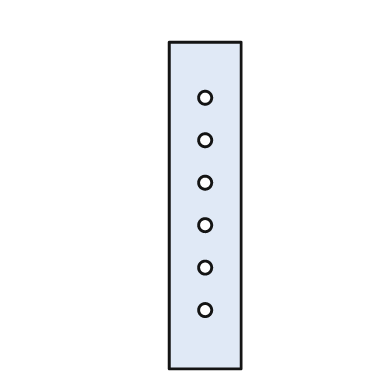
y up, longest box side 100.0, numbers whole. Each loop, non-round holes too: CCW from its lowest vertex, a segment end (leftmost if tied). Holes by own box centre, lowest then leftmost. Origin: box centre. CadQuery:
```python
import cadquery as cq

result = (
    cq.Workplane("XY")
    .moveTo(-11.0, -50.0)
    .lineTo(11.0, -50.0)
    .lineTo(11.0, 50.0)
    .lineTo(-11.0, 50.0)
    .close()
    .moveTo(0.0, -32.0)
    .circle(2.0)
    .moveTo(0.0, -19.0)
    .circle(2.0)
    .moveTo(0.0, -6.0)
    .circle(2.0)
    .moveTo(0.0, 7.0)
    .circle(2.0)
    .moveTo(0.0, 20.0)
    .circle(2.0)
    .moveTo(0.0, 33.0)
    .circle(2.0)
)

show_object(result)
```